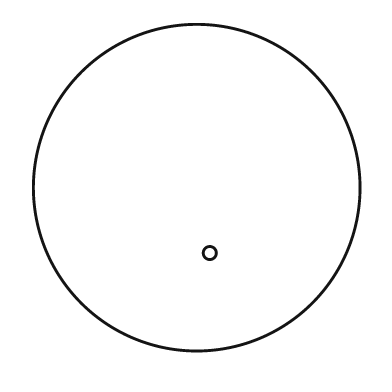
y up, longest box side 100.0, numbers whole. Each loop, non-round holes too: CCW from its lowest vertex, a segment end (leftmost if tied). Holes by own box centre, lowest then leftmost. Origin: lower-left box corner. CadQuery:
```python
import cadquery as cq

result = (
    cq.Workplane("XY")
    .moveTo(50.0, 50.0)
    .circle(50.0)
    .moveTo(54.0, 30.0)
    .circle(2.0)
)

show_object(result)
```